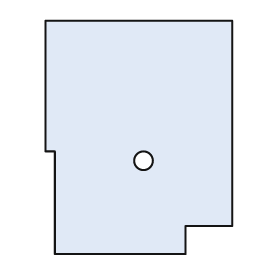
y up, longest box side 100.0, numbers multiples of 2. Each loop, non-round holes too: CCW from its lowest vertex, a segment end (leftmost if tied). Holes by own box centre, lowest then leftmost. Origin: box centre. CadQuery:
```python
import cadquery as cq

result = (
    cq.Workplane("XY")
    .moveTo(-36.0, -50.0)
    .lineTo(20.0, -50.0)
    .lineTo(20.0, -38.0)
    .lineTo(40.0, -38.0)
    .lineTo(40.0, 50.0)
    .lineTo(-40.0, 50.0)
    .lineTo(-40.0, -6.0)
    .lineTo(-36.0, -6.0)
    .close()
    .moveTo(2.0, -10.0)
    .circle(4.0)
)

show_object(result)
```